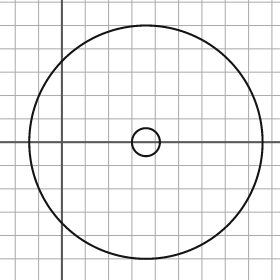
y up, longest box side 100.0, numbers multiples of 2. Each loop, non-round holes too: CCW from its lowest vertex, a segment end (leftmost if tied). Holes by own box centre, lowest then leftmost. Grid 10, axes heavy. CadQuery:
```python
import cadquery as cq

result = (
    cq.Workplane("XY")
    .moveTo(36.0, 0.0)
    .circle(50.0)
    .moveTo(36.0, 0.0)
    .circle(6.0)
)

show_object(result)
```